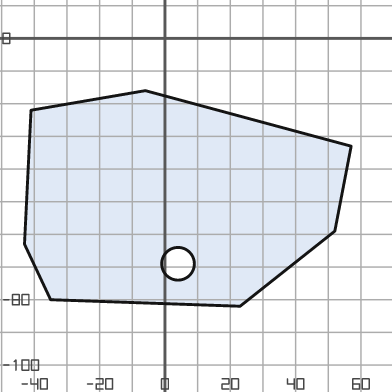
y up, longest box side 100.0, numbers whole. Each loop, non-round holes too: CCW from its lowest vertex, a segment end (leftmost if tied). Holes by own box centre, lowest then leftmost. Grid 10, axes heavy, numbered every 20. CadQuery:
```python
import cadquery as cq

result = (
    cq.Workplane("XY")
    .moveTo(23.0, -82.0)
    .lineTo(52.0, -59.0)
    .lineTo(57.0, -33.0)
    .lineTo(-6.0, -16.0)
    .lineTo(-41.0, -22.0)
    .lineTo(-43.0, -63.0)
    .lineTo(-35.0, -80.0)
    .close()
    .moveTo(4.0, -69.0)
    .circle(5.0)
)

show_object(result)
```